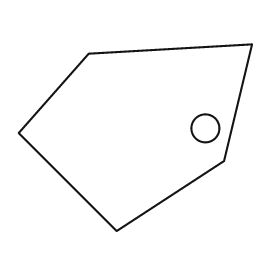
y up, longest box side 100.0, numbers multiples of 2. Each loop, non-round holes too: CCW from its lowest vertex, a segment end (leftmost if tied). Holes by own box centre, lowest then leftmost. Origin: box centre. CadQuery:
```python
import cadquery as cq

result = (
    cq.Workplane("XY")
    .moveTo(-8.0, -40.0)
    .lineTo(38.0, -10.0)
    .lineTo(50.0, 40.0)
    .lineTo(-20.0, 36.0)
    .lineTo(-50.0, 2.0)
    .close()
    .moveTo(30.0, 4.0)
    .circle(6.0)
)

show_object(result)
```